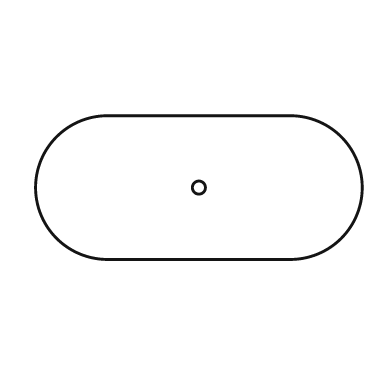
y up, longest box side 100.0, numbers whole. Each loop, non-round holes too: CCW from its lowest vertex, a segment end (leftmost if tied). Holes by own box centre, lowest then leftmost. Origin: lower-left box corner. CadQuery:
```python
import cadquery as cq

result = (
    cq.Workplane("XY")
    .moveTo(22.0, 0.0)
    .lineTo(78.0, 0.0)
    .threePointArc((100.0, 22.0), (78.0, 44.0))
    .lineTo(22.0, 44.0)
    .threePointArc((0.0, 22.0), (22.0, 0.0))
    .close()
    .moveTo(50.0, 22.0)
    .circle(2.0)
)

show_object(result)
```